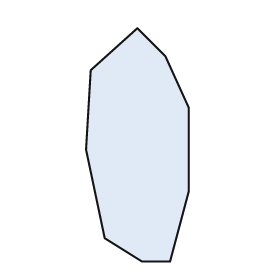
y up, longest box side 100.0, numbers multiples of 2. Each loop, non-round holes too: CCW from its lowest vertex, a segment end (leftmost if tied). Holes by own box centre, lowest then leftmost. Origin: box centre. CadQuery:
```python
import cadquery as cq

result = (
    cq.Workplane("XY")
    .moveTo(2.0, -50.0)
    .lineTo(14.0, -50.0)
    .lineTo(22.0, -20.0)
    .lineTo(22.0, 16.0)
    .lineTo(12.0, 38.0)
    .lineTo(0.0, 50.0)
    .lineTo(-20.0, 32.0)
    .lineTo(-22.0, -2.0)
    .lineTo(-14.0, -40.0)
    .close()
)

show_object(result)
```